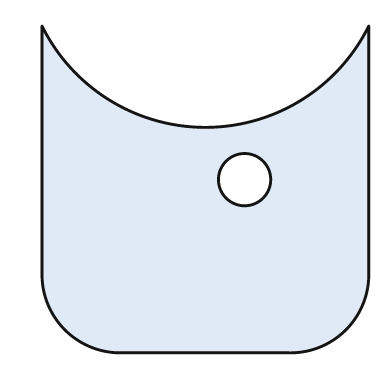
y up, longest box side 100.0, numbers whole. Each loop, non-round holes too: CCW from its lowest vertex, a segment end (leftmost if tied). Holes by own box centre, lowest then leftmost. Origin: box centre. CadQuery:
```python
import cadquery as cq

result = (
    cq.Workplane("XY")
    .moveTo(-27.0, -50.0)
    .lineTo(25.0, -50.0)
    .threePointArc((43.0, -43.0), (50.0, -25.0))
    .lineTo(50.0, 50.0)
    .threePointArc((0.0, 19.0), (-50.0, 50.0))
    .lineTo(-50.0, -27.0)
    .threePointArc((-43.0, -43.0), (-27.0, -50.0))
    .close()
    .moveTo(12.0, 3.0)
    .circle(8.0)
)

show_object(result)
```